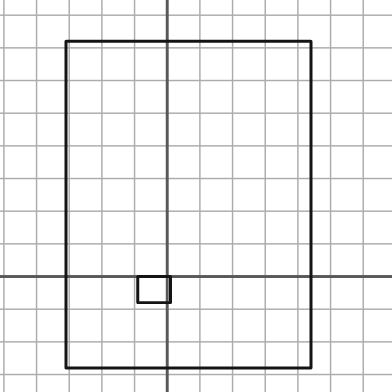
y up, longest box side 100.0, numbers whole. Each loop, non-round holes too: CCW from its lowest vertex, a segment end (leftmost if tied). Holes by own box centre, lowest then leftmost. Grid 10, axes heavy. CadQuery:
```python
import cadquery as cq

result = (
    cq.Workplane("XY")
    .moveTo(-31.0, -28.0)
    .lineTo(44.0, -28.0)
    .lineTo(44.0, 72.0)
    .lineTo(-31.0, 72.0)
    .close()
    .moveTo(-9.0, -8.0)
    .lineTo(1.0, -8.0)
    .lineTo(1.0, 0.0)
    .lineTo(-9.0, 0.0)
    .close()
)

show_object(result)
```